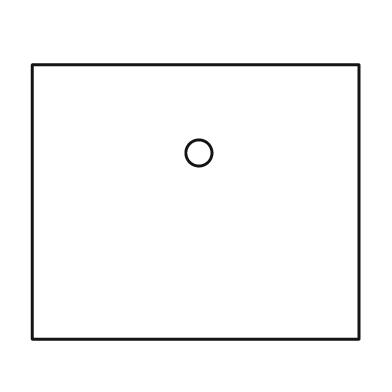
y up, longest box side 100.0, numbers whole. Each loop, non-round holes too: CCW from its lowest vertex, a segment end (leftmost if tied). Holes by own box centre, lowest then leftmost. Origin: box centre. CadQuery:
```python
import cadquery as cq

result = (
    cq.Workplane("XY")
    .moveTo(-50.0, -42.0)
    .lineTo(50.0, -42.0)
    .lineTo(50.0, 42.0)
    .lineTo(-50.0, 42.0)
    .close()
    .moveTo(1.0, 15.0)
    .circle(4.0)
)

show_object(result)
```